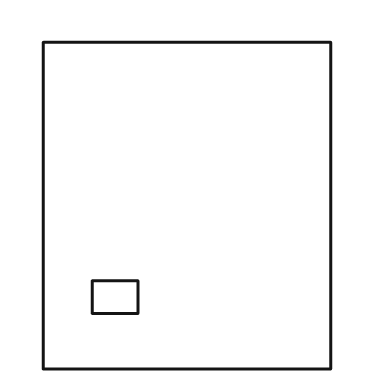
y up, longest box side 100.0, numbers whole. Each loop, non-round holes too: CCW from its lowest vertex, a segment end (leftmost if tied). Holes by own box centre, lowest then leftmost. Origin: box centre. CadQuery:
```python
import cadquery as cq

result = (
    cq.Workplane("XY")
    .moveTo(-44.0, -50.0)
    .lineTo(44.0, -50.0)
    .lineTo(44.0, 50.0)
    .lineTo(-44.0, 50.0)
    .close()
    .moveTo(-29.0, -33.0)
    .lineTo(-15.0, -33.0)
    .lineTo(-15.0, -23.0)
    .lineTo(-29.0, -23.0)
    .close()
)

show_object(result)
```